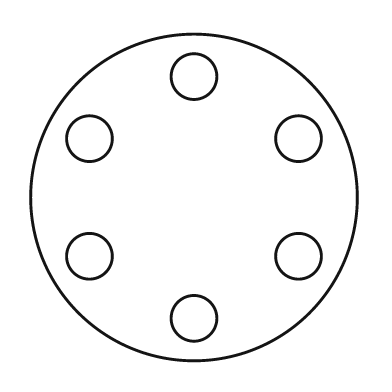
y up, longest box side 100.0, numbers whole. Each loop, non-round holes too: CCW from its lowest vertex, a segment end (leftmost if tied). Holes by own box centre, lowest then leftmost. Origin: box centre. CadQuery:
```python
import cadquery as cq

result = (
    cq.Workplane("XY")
    .moveTo(0.0, 0.0)
    .circle(50.0)
    .moveTo(0.0, -37.0)
    .circle(7.0)
    .moveTo(-32.0, -18.0)
    .circle(7.0)
    .moveTo(32.0, -18.0)
    .circle(7.0)
    .moveTo(-32.0, 18.0)
    .circle(7.0)
    .moveTo(32.0, 18.0)
    .circle(7.0)
    .moveTo(0.0, 37.0)
    .circle(7.0)
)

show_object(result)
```